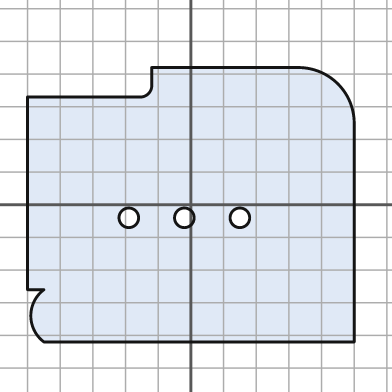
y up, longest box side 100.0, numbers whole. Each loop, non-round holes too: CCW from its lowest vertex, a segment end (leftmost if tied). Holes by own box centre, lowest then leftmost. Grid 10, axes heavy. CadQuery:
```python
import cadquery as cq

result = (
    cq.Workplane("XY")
    .moveTo(-45.0, -42.0)
    .lineTo(50.0, -42.0)
    .lineTo(50.0, 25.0)
    .threePointArc((45.0, 37.0), (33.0, 42.0))
    .lineTo(-12.0, 42.0)
    .lineTo(-12.0, 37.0)
    .threePointArc((-13.0, 34.0), (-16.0, 33.0))
    .lineTo(-50.0, 33.0)
    .lineTo(-50.0, -26.0)
    .lineTo(-45.0, -26.0)
    .threePointArc((-49.0, -34.0), (-45.0, -42.0))
    .close()
    .moveTo(-19.0, -4.0)
    .circle(3.0)
    .moveTo(-2.0, -4.0)
    .circle(3.0)
    .moveTo(15.0, -4.0)
    .circle(3.0)
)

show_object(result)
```